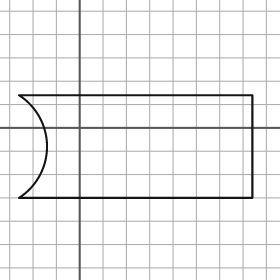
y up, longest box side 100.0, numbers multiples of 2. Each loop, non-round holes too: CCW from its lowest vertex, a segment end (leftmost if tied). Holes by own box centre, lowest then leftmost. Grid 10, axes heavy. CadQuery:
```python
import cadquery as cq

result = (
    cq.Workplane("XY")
    .moveTo(-26.0, -30.0)
    .lineTo(74.0, -30.0)
    .lineTo(74.0, 14.0)
    .lineTo(-26.0, 14.0)
    .threePointArc((-14.0, -8.0), (-26.0, -30.0))
    .close()
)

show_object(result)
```